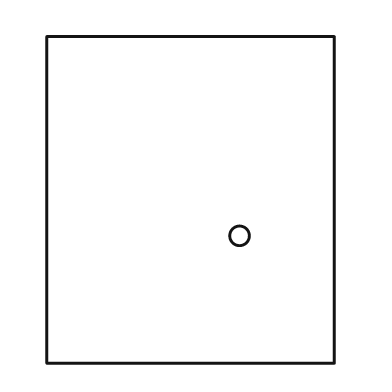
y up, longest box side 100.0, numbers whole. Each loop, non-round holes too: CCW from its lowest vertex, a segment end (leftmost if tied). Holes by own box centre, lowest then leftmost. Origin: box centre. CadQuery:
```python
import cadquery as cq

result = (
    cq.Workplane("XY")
    .moveTo(-44.0, -50.0)
    .lineTo(44.0, -50.0)
    .lineTo(44.0, 50.0)
    .lineTo(-44.0, 50.0)
    .close()
    .moveTo(15.0, -11.0)
    .circle(3.0)
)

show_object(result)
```